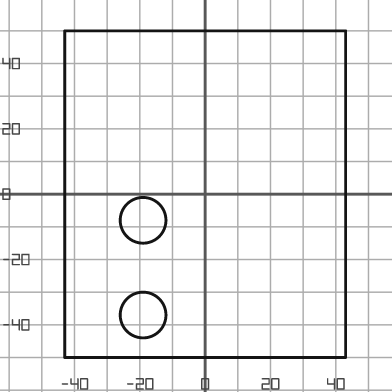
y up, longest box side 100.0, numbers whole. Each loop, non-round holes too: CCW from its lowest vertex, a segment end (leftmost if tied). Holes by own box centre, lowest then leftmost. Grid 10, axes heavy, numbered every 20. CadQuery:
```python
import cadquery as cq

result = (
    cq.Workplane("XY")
    .moveTo(-43.0, -50.0)
    .lineTo(43.0, -50.0)
    .lineTo(43.0, 50.0)
    .lineTo(-43.0, 50.0)
    .close()
    .moveTo(-19.0, -37.0)
    .circle(7.0)
    .moveTo(-19.0, -8.0)
    .circle(7.0)
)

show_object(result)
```